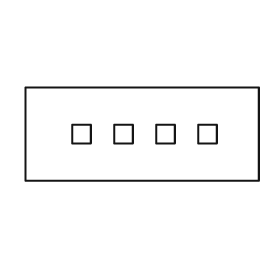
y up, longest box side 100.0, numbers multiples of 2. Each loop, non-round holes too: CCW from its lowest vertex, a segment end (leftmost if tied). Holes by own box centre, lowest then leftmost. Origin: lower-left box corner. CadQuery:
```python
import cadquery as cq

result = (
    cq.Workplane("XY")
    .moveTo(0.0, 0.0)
    .lineTo(100.0, 0.0)
    .lineTo(100.0, 40.0)
    .lineTo(0.0, 40.0)
    .close()
    .moveTo(20.0, 16.0)
    .lineTo(28.0, 16.0)
    .lineTo(28.0, 24.0)
    .lineTo(20.0, 24.0)
    .close()
    .moveTo(38.0, 16.0)
    .lineTo(46.0, 16.0)
    .lineTo(46.0, 24.0)
    .lineTo(38.0, 24.0)
    .close()
    .moveTo(56.0, 16.0)
    .lineTo(64.0, 16.0)
    .lineTo(64.0, 24.0)
    .lineTo(56.0, 24.0)
    .close()
    .moveTo(74.0, 16.0)
    .lineTo(82.0, 16.0)
    .lineTo(82.0, 24.0)
    .lineTo(74.0, 24.0)
    .close()
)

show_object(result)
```